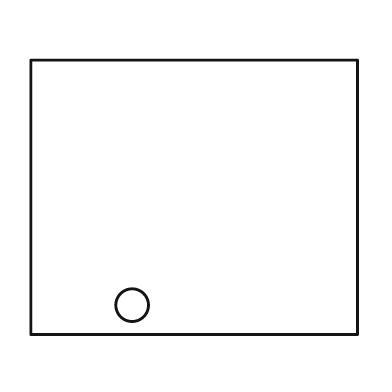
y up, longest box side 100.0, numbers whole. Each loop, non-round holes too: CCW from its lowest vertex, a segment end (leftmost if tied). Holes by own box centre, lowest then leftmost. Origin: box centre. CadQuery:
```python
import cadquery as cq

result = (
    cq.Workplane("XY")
    .moveTo(-50.0, -42.0)
    .lineTo(50.0, -42.0)
    .lineTo(50.0, 42.0)
    .lineTo(-50.0, 42.0)
    .close()
    .moveTo(-19.0, -33.0)
    .circle(5.0)
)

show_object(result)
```